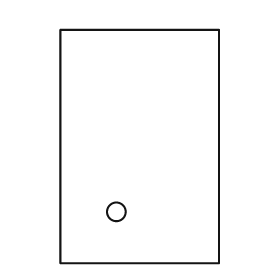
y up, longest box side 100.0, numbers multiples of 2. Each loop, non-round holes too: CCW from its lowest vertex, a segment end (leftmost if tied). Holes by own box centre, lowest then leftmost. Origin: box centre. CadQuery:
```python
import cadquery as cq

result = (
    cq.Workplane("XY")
    .moveTo(-34.0, -50.0)
    .lineTo(34.0, -50.0)
    .lineTo(34.0, 50.0)
    .lineTo(-34.0, 50.0)
    .close()
    .moveTo(-10.0, -28.0)
    .circle(4.0)
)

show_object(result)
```